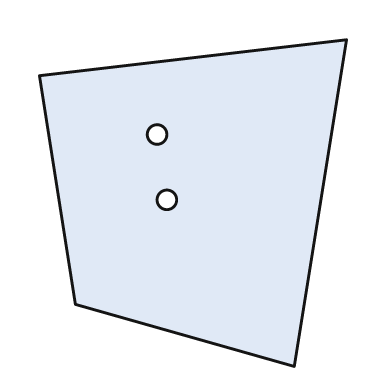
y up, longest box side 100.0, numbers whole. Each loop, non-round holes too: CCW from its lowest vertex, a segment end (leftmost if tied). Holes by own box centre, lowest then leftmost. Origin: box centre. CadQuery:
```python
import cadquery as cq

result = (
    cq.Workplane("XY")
    .moveTo(31.0, -50.0)
    .lineTo(47.0, 50.0)
    .lineTo(-47.0, 39.0)
    .lineTo(-36.0, -31.0)
    .close()
    .moveTo(-8.0, 1.0)
    .circle(3.0)
    .moveTo(-11.0, 21.0)
    .circle(3.0)
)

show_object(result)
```